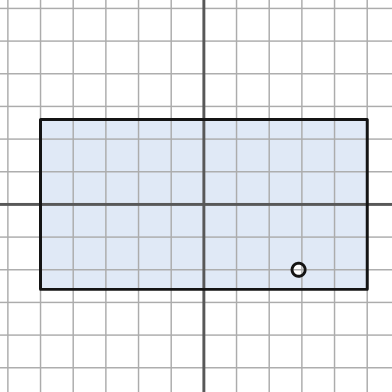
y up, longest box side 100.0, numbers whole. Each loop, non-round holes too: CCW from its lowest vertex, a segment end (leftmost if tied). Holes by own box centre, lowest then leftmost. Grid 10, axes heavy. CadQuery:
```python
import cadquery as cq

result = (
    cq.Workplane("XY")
    .moveTo(-50.0, -26.0)
    .lineTo(50.0, -26.0)
    .lineTo(50.0, 26.0)
    .lineTo(-50.0, 26.0)
    .close()
    .moveTo(29.0, -20.0)
    .circle(2.0)
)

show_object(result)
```